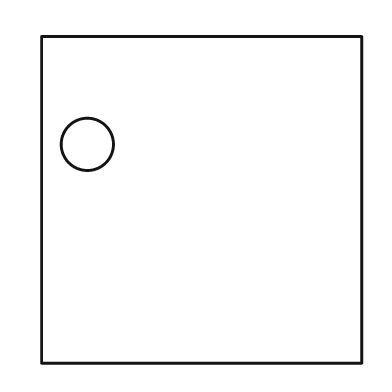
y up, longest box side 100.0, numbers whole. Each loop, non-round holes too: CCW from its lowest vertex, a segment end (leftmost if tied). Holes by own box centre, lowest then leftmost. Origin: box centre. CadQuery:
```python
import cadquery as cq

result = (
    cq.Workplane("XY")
    .moveTo(-49.0, -50.0)
    .lineTo(49.0, -50.0)
    .lineTo(49.0, 50.0)
    .lineTo(-49.0, 50.0)
    .close()
    .moveTo(-35.0, 17.0)
    .circle(8.0)
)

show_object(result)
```